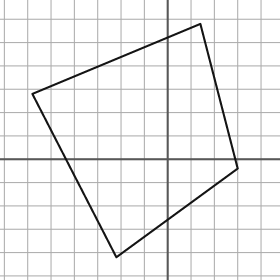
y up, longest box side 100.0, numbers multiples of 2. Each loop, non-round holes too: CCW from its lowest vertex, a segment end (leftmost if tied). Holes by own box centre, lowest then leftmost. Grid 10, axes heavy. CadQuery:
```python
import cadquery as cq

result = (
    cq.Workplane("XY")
    .moveTo(-22.0, -42.0)
    .lineTo(30.0, -4.0)
    .lineTo(14.0, 58.0)
    .lineTo(-58.0, 28.0)
    .close()
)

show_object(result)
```